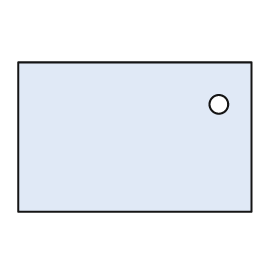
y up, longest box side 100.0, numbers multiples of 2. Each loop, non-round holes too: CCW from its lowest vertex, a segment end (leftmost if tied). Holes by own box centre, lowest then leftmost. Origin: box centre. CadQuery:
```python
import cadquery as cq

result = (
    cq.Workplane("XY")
    .moveTo(-50.0, -32.0)
    .lineTo(50.0, -32.0)
    .lineTo(50.0, 32.0)
    .lineTo(-50.0, 32.0)
    .close()
    .moveTo(36.0, 14.0)
    .circle(4.0)
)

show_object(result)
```